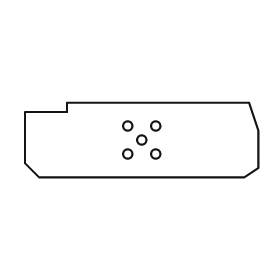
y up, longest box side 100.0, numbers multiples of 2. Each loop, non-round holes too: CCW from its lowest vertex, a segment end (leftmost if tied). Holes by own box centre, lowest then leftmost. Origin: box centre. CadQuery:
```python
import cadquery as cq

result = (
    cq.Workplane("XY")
    .moveTo(-44.0, -16.0)
    .lineTo(44.0, -16.0)
    .lineTo(50.0, -12.0)
    .lineTo(50.0, 4.0)
    .lineTo(46.0, 16.0)
    .lineTo(-32.0, 16.0)
    .lineTo(-32.0, 12.0)
    .lineTo(-50.0, 12.0)
    .lineTo(-50.0, -10.0)
    .close()
    .moveTo(-6.0, -6.0)
    .circle(2.0)
    .moveTo(6.0, -6.0)
    .circle(2.0)
    .moveTo(0.0, 0.0)
    .circle(2.0)
    .moveTo(-6.0, 6.0)
    .circle(2.0)
    .moveTo(6.0, 6.0)
    .circle(2.0)
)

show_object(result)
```